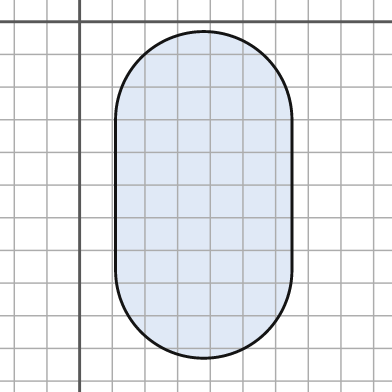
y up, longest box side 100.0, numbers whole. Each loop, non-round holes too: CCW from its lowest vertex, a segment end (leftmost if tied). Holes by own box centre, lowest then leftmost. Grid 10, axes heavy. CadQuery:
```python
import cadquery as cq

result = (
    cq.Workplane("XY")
    .moveTo(11.0, -76.0)
    .threePointArc((38.0, -103.0), (65.0, -76.0))
    .lineTo(65.0, -30.0)
    .threePointArc((38.0, -3.0), (11.0, -30.0))
    .close()
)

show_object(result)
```